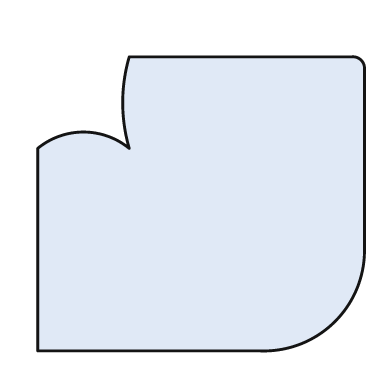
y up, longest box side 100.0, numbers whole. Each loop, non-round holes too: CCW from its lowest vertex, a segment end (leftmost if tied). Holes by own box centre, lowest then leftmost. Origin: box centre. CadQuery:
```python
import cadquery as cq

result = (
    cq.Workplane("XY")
    .moveTo(-50.0, -45.0)
    .lineTo(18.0, -45.0)
    .threePointArc((41.0, -36.0), (50.0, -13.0))
    .lineTo(50.0, 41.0)
    .threePointArc((49.0, 44.0), (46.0, 45.0))
    .lineTo(-22.0, 45.0)
    .threePointArc((-24.0, 31.0), (-22.0, 17.0))
    .threePointArc((-36.0, 22.0), (-50.0, 17.0))
    .close()
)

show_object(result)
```